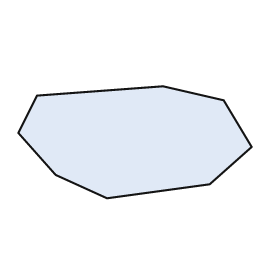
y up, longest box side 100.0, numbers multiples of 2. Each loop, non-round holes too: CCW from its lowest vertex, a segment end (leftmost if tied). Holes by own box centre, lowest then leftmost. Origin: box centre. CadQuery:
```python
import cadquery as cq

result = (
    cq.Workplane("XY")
    .moveTo(-12.0, -24.0)
    .lineTo(32.0, -18.0)
    .lineTo(50.0, -2.0)
    .lineTo(38.0, 18.0)
    .lineTo(12.0, 24.0)
    .lineTo(-42.0, 20.0)
    .lineTo(-50.0, 4.0)
    .lineTo(-34.0, -14.0)
    .close()
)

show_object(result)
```